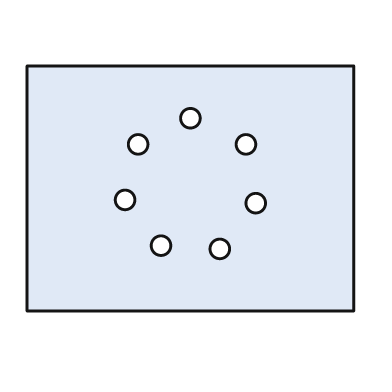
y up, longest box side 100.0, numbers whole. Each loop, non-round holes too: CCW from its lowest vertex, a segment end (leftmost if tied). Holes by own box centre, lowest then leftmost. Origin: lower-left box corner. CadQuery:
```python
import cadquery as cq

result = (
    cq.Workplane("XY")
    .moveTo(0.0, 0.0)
    .lineTo(100.0, 0.0)
    .lineTo(100.0, 75.0)
    .lineTo(0.0, 75.0)
    .close()
    .moveTo(59.0, 19.0)
    .circle(3.0)
    .moveTo(41.0, 20.0)
    .circle(3.0)
    .moveTo(70.0, 33.0)
    .circle(3.0)
    .moveTo(30.0, 34.0)
    .circle(3.0)
    .moveTo(34.0, 51.0)
    .circle(3.0)
    .moveTo(67.0, 51.0)
    .circle(3.0)
    .moveTo(50.0, 59.0)
    .circle(3.0)
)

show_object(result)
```